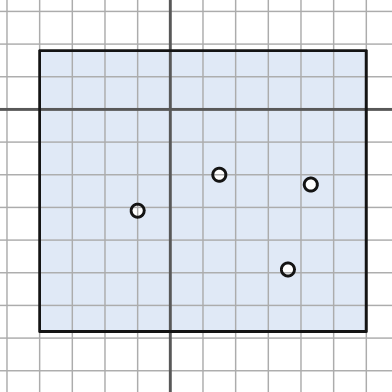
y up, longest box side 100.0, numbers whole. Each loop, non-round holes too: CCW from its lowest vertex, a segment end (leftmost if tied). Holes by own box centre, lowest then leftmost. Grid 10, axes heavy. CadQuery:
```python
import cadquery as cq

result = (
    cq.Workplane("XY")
    .moveTo(-40.0, -68.0)
    .lineTo(60.0, -68.0)
    .lineTo(60.0, 18.0)
    .lineTo(-40.0, 18.0)
    .close()
    .moveTo(36.0, -49.0)
    .circle(2.0)
    .moveTo(-10.0, -31.0)
    .circle(2.0)
    .moveTo(43.0, -23.0)
    .circle(2.0)
    .moveTo(15.0, -20.0)
    .circle(2.0)
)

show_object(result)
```